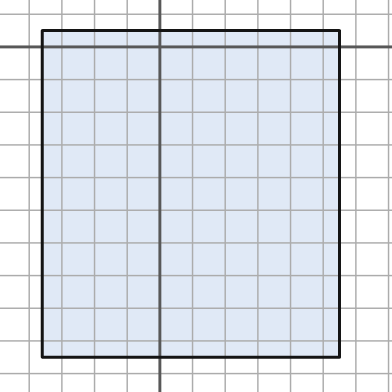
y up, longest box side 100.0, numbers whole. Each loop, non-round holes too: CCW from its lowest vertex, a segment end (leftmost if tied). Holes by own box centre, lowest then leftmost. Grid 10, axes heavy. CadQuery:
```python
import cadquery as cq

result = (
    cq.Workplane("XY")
    .moveTo(-36.0, -95.0)
    .lineTo(55.0, -95.0)
    .lineTo(55.0, 5.0)
    .lineTo(-36.0, 5.0)
    .close()
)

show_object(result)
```